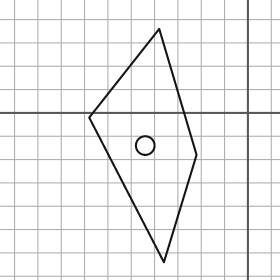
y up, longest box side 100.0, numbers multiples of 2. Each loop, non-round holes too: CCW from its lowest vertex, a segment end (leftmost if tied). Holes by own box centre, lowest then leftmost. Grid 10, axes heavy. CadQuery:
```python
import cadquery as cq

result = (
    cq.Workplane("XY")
    .moveTo(-36.0, -64.0)
    .lineTo(-22.0, -18.0)
    .lineTo(-38.0, 36.0)
    .lineTo(-68.0, -2.0)
    .close()
    .moveTo(-44.0, -14.0)
    .circle(4.0)
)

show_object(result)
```